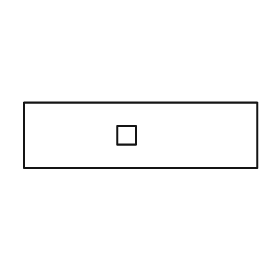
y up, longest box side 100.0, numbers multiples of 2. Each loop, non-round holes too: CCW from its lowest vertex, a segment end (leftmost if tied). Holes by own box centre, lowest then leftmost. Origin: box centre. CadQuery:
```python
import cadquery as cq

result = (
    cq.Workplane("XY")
    .moveTo(-50.0, -14.0)
    .lineTo(50.0, -14.0)
    .lineTo(50.0, 14.0)
    .lineTo(-50.0, 14.0)
    .close()
    .moveTo(-10.0, -4.0)
    .lineTo(-2.0, -4.0)
    .lineTo(-2.0, 4.0)
    .lineTo(-10.0, 4.0)
    .close()
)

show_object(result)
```